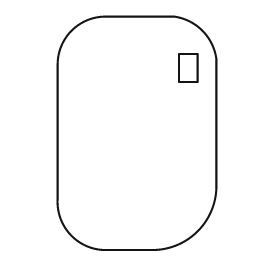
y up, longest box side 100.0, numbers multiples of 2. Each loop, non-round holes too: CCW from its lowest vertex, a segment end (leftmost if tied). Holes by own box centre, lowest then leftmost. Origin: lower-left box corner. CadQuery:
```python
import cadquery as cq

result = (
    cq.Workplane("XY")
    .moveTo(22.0, 0.0)
    .lineTo(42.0, 0.0)
    .threePointArc((60.0, 8.0), (68.0, 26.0))
    .lineTo(68.0, 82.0)
    .threePointArc((62.0, 94.0), (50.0, 100.0))
    .lineTo(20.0, 100.0)
    .threePointArc((6.0, 94.0), (0.0, 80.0))
    .lineTo(0.0, 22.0)
    .threePointArc((6.0, 6.0), (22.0, 0.0))
    .close()
    .moveTo(52.0, 72.0)
    .lineTo(60.0, 72.0)
    .lineTo(60.0, 84.0)
    .lineTo(52.0, 84.0)
    .close()
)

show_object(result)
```